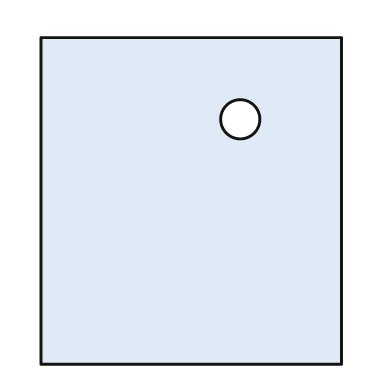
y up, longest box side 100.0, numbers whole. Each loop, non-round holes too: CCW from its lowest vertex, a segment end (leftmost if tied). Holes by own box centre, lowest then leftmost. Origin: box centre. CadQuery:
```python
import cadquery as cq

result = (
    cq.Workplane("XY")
    .moveTo(-46.0, -50.0)
    .lineTo(46.0, -50.0)
    .lineTo(46.0, 50.0)
    .lineTo(-46.0, 50.0)
    .close()
    .moveTo(15.0, 25.0)
    .circle(6.0)
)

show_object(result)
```